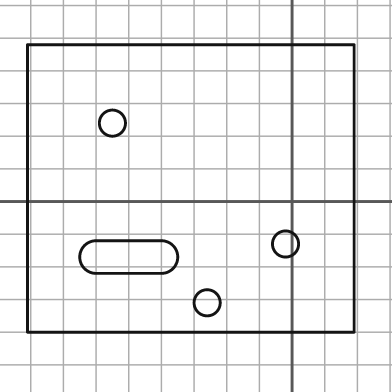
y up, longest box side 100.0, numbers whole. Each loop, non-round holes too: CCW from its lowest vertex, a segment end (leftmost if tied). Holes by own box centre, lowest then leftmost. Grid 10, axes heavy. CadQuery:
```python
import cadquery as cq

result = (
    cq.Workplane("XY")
    .moveTo(-81.0, -40.0)
    .lineTo(19.0, -40.0)
    .lineTo(19.0, 48.0)
    .lineTo(-81.0, 48.0)
    .close()
    .moveTo(-26.0, -31.0)
    .circle(4.0)
    .moveTo(-60.0, -22.0)
    .lineTo(-40.0, -22.0)
    .threePointArc((-35.0, -17.0), (-40.0, -12.0))
    .lineTo(-60.0, -12.0)
    .threePointArc((-65.0, -17.0), (-60.0, -22.0))
    .close()
    .moveTo(-2.0, -13.0)
    .circle(4.0)
    .moveTo(-55.0, 24.0)
    .circle(4.0)
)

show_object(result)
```